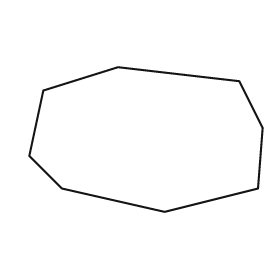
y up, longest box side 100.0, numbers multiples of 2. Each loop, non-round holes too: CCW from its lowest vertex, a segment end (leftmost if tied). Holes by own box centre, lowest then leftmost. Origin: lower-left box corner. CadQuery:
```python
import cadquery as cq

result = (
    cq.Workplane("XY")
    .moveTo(58.0, 0.0)
    .lineTo(98.0, 10.0)
    .lineTo(100.0, 36.0)
    .lineTo(90.0, 56.0)
    .lineTo(38.0, 62.0)
    .lineTo(6.0, 52.0)
    .lineTo(0.0, 24.0)
    .lineTo(14.0, 10.0)
    .close()
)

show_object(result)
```